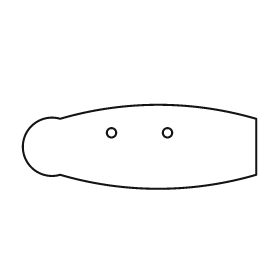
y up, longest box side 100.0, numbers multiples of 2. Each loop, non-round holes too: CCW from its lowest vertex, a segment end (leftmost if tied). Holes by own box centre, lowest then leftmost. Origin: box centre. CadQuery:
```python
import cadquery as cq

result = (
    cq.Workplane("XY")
    .moveTo(-34.0, -12.0)
    .threePointArc((8.0, -18.0), (50.0, -12.0))
    .lineTo(50.0, 12.0)
    .threePointArc((8.0, 18.0), (-34.0, 12.0))
    .threePointArc((-50.0, 0.0), (-34.0, -12.0))
    .close()
    .moveTo(-12.0, 6.0)
    .circle(2.0)
    .moveTo(12.0, 6.0)
    .circle(2.0)
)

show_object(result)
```